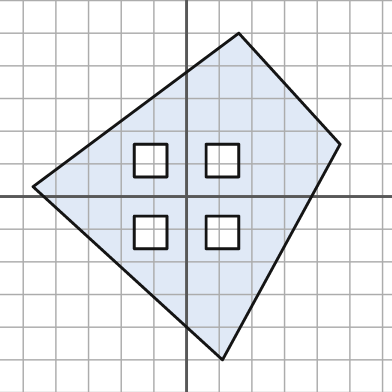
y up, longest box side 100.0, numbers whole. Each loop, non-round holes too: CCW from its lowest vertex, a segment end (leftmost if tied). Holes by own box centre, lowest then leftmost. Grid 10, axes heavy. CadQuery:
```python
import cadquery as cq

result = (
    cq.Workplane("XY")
    .moveTo(11.0, -50.0)
    .lineTo(47.0, 16.0)
    .lineTo(16.0, 50.0)
    .lineTo(-47.0, 3.0)
    .close()
    .moveTo(-16.0, -16.0)
    .lineTo(-6.0, -16.0)
    .lineTo(-6.0, -6.0)
    .lineTo(-16.0, -6.0)
    .close()
    .moveTo(6.0, -16.0)
    .lineTo(16.0, -16.0)
    .lineTo(16.0, -6.0)
    .lineTo(6.0, -6.0)
    .close()
    .moveTo(-16.0, 6.0)
    .lineTo(-6.0, 6.0)
    .lineTo(-6.0, 16.0)
    .lineTo(-16.0, 16.0)
    .close()
    .moveTo(6.0, 6.0)
    .lineTo(16.0, 6.0)
    .lineTo(16.0, 16.0)
    .lineTo(6.0, 16.0)
    .close()
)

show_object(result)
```